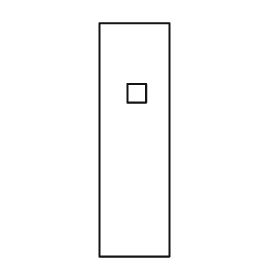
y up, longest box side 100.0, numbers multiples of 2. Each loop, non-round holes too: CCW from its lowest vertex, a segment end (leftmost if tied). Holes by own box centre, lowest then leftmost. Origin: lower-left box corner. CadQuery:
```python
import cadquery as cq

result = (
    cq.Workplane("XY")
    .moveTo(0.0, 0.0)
    .lineTo(30.0, 0.0)
    .lineTo(30.0, 100.0)
    .lineTo(0.0, 100.0)
    .close()
    .moveTo(12.0, 66.0)
    .lineTo(20.0, 66.0)
    .lineTo(20.0, 74.0)
    .lineTo(12.0, 74.0)
    .close()
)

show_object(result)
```